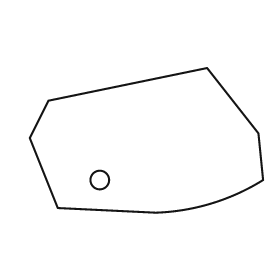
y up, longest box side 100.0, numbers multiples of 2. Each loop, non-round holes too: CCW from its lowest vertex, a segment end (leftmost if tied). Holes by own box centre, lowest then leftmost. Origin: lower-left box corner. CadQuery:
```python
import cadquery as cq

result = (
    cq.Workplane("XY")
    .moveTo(54.0, 0.0)
    .threePointArc((78.0, 4.0), (100.0, 14.0))
    .lineTo(98.0, 34.0)
    .lineTo(76.0, 62.0)
    .lineTo(8.0, 48.0)
    .lineTo(0.0, 32.0)
    .lineTo(12.0, 2.0)
    .close()
    .moveTo(30.0, 14.0)
    .circle(4.0)
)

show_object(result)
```